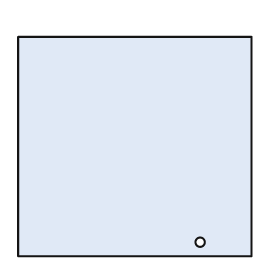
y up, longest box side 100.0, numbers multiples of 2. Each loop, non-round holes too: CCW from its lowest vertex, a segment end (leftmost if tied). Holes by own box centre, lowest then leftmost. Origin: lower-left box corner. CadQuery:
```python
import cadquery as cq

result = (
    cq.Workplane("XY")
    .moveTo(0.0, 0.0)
    .lineTo(100.0, 0.0)
    .lineTo(100.0, 94.0)
    .lineTo(0.0, 94.0)
    .close()
    .moveTo(78.0, 6.0)
    .circle(2.0)
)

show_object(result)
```